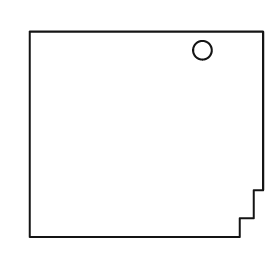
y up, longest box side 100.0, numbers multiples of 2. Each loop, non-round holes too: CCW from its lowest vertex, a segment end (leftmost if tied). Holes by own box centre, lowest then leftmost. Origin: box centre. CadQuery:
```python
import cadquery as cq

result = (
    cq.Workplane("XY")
    .moveTo(-50.0, -44.0)
    .lineTo(40.0, -44.0)
    .lineTo(40.0, -36.0)
    .lineTo(46.0, -36.0)
    .lineTo(46.0, -24.0)
    .lineTo(50.0, -24.0)
    .lineTo(50.0, 44.0)
    .lineTo(-50.0, 44.0)
    .close()
    .moveTo(24.0, 36.0)
    .circle(4.0)
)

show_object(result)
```